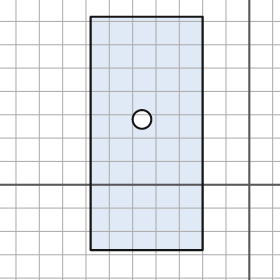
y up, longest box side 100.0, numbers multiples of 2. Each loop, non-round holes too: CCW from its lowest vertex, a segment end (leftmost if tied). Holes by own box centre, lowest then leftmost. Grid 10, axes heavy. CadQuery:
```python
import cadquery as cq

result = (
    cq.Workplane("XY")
    .moveTo(-68.0, -28.0)
    .lineTo(-20.0, -28.0)
    .lineTo(-20.0, 72.0)
    .lineTo(-68.0, 72.0)
    .close()
    .moveTo(-46.0, 28.0)
    .circle(4.0)
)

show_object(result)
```